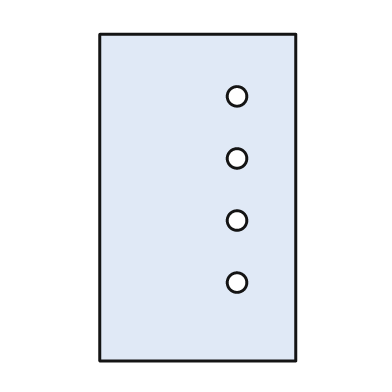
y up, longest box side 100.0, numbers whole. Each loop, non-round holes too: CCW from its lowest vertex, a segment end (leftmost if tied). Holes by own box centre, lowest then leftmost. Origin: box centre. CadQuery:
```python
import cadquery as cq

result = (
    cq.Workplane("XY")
    .moveTo(-30.0, -50.0)
    .lineTo(30.0, -50.0)
    .lineTo(30.0, 50.0)
    .lineTo(-30.0, 50.0)
    .close()
    .moveTo(12.0, -26.0)
    .circle(3.0)
    .moveTo(12.0, -7.0)
    .circle(3.0)
    .moveTo(12.0, 12.0)
    .circle(3.0)
    .moveTo(12.0, 31.0)
    .circle(3.0)
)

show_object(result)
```